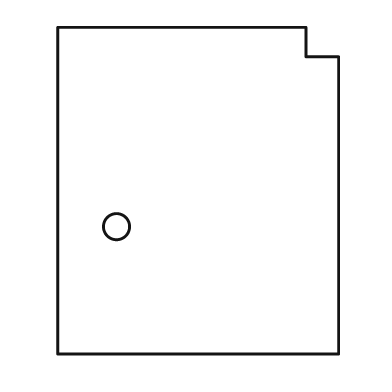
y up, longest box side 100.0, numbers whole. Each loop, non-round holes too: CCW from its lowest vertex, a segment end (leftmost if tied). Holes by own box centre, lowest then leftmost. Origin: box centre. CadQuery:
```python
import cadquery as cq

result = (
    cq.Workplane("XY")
    .moveTo(-43.0, -50.0)
    .lineTo(43.0, -50.0)
    .lineTo(43.0, 41.0)
    .lineTo(33.0, 41.0)
    .lineTo(33.0, 50.0)
    .lineTo(-43.0, 50.0)
    .close()
    .moveTo(-25.0, -11.0)
    .circle(4.0)
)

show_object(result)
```